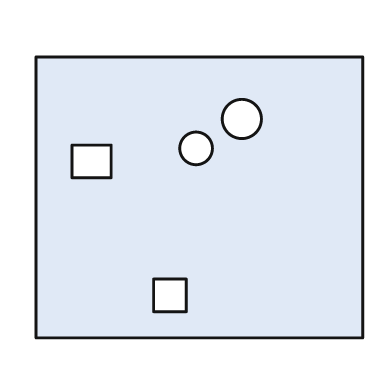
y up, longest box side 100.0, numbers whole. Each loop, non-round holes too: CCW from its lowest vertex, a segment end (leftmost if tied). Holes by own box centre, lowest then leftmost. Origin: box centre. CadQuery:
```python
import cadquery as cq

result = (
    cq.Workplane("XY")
    .moveTo(-50.0, -43.0)
    .lineTo(50.0, -43.0)
    .lineTo(50.0, 43.0)
    .lineTo(-50.0, 43.0)
    .close()
    .moveTo(-14.0, -35.0)
    .lineTo(-4.0, -35.0)
    .lineTo(-4.0, -25.0)
    .lineTo(-14.0, -25.0)
    .close()
    .moveTo(-39.0, 6.0)
    .lineTo(-27.0, 6.0)
    .lineTo(-27.0, 16.0)
    .lineTo(-39.0, 16.0)
    .close()
    .moveTo(-1.0, 15.0)
    .circle(5.0)
    .moveTo(13.0, 24.0)
    .circle(6.0)
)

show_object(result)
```